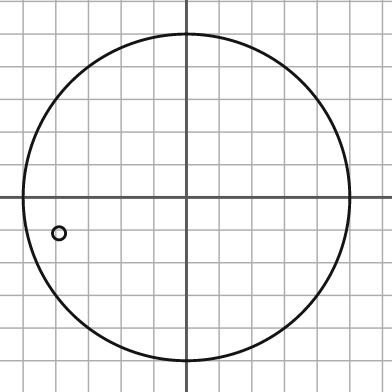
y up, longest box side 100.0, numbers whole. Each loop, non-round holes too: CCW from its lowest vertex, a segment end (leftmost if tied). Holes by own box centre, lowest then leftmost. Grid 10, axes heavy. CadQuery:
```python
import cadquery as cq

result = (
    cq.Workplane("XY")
    .moveTo(0.0, 0.0)
    .circle(50.0)
    .moveTo(-39.0, -11.0)
    .circle(2.0)
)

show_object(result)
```